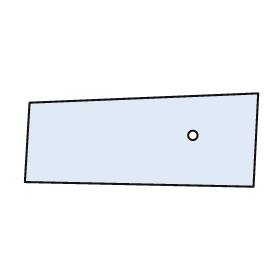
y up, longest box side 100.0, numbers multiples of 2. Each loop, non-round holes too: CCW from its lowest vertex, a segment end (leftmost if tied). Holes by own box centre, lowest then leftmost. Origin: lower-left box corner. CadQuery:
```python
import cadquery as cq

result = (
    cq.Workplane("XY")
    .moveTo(98.0, 0.0)
    .lineTo(100.0, 40.0)
    .lineTo(2.0, 36.0)
    .lineTo(0.0, 2.0)
    .close()
    .moveTo(72.0, 22.0)
    .circle(2.0)
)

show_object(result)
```